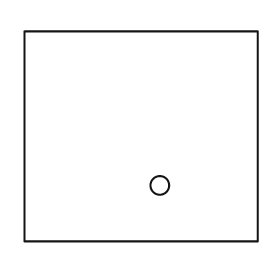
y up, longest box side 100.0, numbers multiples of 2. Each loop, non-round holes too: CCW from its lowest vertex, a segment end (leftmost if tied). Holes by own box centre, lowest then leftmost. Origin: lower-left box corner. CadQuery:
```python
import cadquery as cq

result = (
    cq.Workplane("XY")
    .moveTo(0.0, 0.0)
    .lineTo(100.0, 0.0)
    .lineTo(100.0, 90.0)
    .lineTo(0.0, 90.0)
    .close()
    .moveTo(58.0, 24.0)
    .circle(4.0)
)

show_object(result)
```